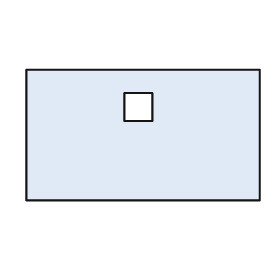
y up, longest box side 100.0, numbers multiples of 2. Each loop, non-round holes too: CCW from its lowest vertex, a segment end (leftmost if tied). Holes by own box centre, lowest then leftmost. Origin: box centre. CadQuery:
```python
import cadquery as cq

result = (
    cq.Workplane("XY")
    .moveTo(-50.0, -28.0)
    .lineTo(50.0, -28.0)
    .lineTo(50.0, 28.0)
    .lineTo(-50.0, 28.0)
    .close()
    .moveTo(-8.0, 6.0)
    .lineTo(4.0, 6.0)
    .lineTo(4.0, 18.0)
    .lineTo(-8.0, 18.0)
    .close()
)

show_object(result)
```